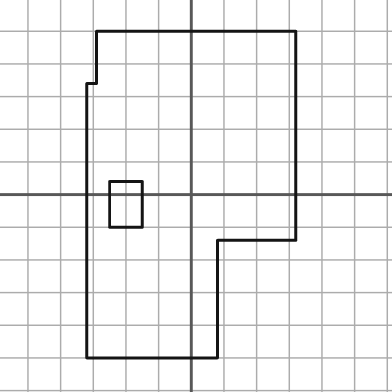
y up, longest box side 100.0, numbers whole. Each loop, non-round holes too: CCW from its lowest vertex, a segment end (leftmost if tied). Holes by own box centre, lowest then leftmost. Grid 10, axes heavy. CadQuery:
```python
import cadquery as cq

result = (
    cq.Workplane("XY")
    .moveTo(-32.0, -50.0)
    .lineTo(8.0, -50.0)
    .lineTo(8.0, -14.0)
    .lineTo(32.0, -14.0)
    .lineTo(32.0, 50.0)
    .lineTo(-29.0, 50.0)
    .lineTo(-29.0, 34.0)
    .lineTo(-32.0, 34.0)
    .close()
    .moveTo(-25.0, -10.0)
    .lineTo(-15.0, -10.0)
    .lineTo(-15.0, 4.0)
    .lineTo(-25.0, 4.0)
    .close()
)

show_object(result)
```